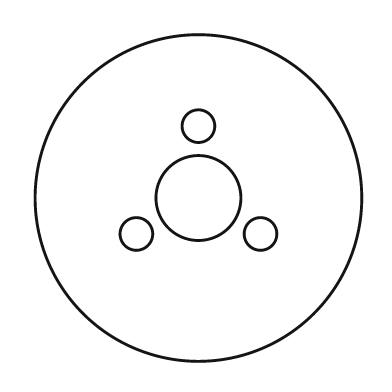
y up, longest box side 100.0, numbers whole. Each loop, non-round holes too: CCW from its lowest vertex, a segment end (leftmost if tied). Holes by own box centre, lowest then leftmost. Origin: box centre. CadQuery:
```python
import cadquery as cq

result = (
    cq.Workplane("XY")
    .moveTo(0.0, 0.0)
    .circle(50.0)
    .moveTo(-19.0, -11.0)
    .circle(5.0)
    .moveTo(19.0, -11.0)
    .circle(5.0)
    .moveTo(0.0, 0.0)
    .circle(13.0)
    .moveTo(0.0, 22.0)
    .circle(5.0)
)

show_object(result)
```